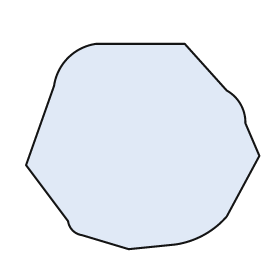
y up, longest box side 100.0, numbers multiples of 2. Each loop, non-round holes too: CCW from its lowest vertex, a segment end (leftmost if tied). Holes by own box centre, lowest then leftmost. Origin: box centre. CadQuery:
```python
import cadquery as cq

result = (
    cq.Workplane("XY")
    .moveTo(-6.0, -44.0)
    .lineTo(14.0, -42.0)
    .threePointArc((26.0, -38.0), (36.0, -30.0))
    .lineTo(50.0, -4.0)
    .lineTo(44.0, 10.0)
    .threePointArc((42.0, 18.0), (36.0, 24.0))
    .lineTo(18.0, 44.0)
    .lineTo(-20.0, 44.0)
    .threePointArc((-32.0, 38.0), (-38.0, 26.0))
    .lineTo(-50.0, -8.0)
    .lineTo(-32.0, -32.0)
    .threePointArc((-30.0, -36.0), (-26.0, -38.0))
    .close()
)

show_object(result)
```